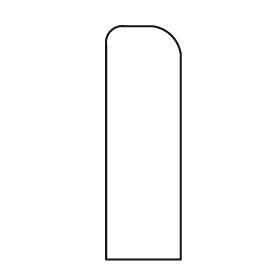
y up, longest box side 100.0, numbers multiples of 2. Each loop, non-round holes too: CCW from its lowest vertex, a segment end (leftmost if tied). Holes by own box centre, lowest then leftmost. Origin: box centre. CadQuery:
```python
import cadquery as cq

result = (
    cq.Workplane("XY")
    .moveTo(-16.0, -50.0)
    .lineTo(16.0, -50.0)
    .lineTo(16.0, 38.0)
    .threePointArc((12.0, 46.0), (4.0, 50.0))
    .lineTo(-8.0, 50.0)
    .threePointArc((-14.0, 48.0), (-16.0, 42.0))
    .close()
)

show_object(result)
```